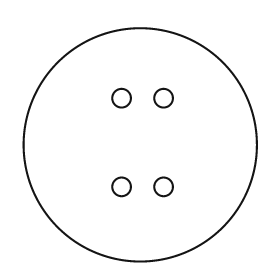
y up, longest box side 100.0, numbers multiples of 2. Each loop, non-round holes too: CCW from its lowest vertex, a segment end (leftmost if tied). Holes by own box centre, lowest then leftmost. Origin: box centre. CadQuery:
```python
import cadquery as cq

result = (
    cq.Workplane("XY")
    .moveTo(0.0, 0.0)
    .circle(50.0)
    .moveTo(-8.0, -18.0)
    .circle(4.0)
    .moveTo(10.0, -18.0)
    .circle(4.0)
    .moveTo(-8.0, 20.0)
    .circle(4.0)
    .moveTo(10.0, 20.0)
    .circle(4.0)
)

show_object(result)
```